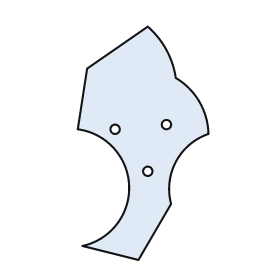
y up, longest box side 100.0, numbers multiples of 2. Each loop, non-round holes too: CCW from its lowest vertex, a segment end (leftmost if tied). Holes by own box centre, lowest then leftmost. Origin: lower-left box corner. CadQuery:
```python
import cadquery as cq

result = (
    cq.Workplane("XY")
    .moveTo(26.0, 0.0)
    .lineTo(40.0, 24.0)
    .threePointArc((42.0, 42.0), (56.0, 54.0))
    .threePointArc((52.0, 68.0), (42.0, 78.0))
    .threePointArc((38.0, 90.0), (30.0, 100.0))
    .lineTo(4.0, 82.0)
    .lineTo(0.0, 56.0)
    .threePointArc((22.0, 32.0), (2.0, 6.0))
    .close()
    .moveTo(30.0, 38.0)
    .circle(2.0)
    .moveTo(16.0, 56.0)
    .circle(2.0)
    .moveTo(38.0, 58.0)
    .circle(2.0)
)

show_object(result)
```